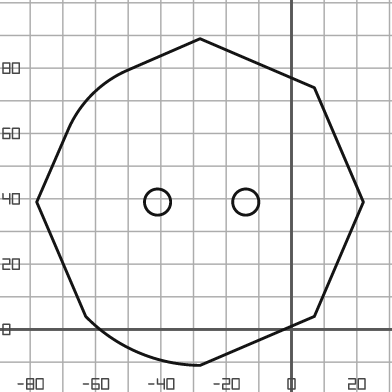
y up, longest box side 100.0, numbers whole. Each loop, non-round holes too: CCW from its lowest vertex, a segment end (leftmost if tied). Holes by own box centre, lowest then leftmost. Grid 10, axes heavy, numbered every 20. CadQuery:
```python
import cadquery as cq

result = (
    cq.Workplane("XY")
    .moveTo(-28.0, -11.0)
    .lineTo(7.0, 4.0)
    .lineTo(22.0, 39.0)
    .lineTo(7.0, 74.0)
    .lineTo(-28.0, 89.0)
    .lineTo(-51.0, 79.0)
    .threePointArc((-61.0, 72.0), (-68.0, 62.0))
    .lineTo(-78.0, 39.0)
    .lineTo(-63.0, 4.0)
    .threePointArc((-47.0, -7.0), (-28.0, -11.0))
    .close()
    .moveTo(-41.0, 39.0)
    .circle(4.0)
    .moveTo(-14.0, 39.0)
    .circle(4.0)
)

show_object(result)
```